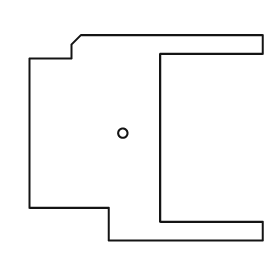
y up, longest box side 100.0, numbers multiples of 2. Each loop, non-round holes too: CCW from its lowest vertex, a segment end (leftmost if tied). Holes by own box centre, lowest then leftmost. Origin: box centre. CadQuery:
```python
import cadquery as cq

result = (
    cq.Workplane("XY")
    .moveTo(-16.0, -44.0)
    .lineTo(50.0, -44.0)
    .lineTo(50.0, -36.0)
    .lineTo(6.0, -36.0)
    .lineTo(6.0, 36.0)
    .lineTo(50.0, 36.0)
    .lineTo(50.0, 44.0)
    .lineTo(-28.0, 44.0)
    .lineTo(-32.0, 40.0)
    .lineTo(-32.0, 34.0)
    .lineTo(-50.0, 34.0)
    .lineTo(-50.0, -30.0)
    .lineTo(-16.0, -30.0)
    .close()
    .moveTo(-10.0, 2.0)
    .circle(2.0)
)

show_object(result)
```